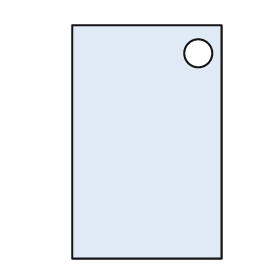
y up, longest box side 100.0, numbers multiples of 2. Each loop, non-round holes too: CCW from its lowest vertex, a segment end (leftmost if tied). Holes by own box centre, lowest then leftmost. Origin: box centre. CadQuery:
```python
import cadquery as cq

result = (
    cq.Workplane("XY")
    .moveTo(-32.0, -50.0)
    .lineTo(32.0, -50.0)
    .lineTo(32.0, 50.0)
    .lineTo(-32.0, 50.0)
    .close()
    .moveTo(22.0, 38.0)
    .circle(6.0)
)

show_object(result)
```